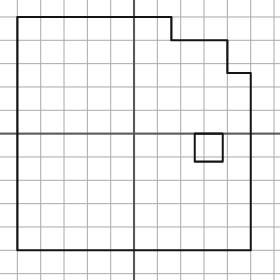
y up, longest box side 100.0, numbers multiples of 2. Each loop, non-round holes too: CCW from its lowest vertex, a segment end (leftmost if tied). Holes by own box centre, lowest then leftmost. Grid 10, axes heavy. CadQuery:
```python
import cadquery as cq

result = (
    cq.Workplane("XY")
    .moveTo(-50.0, -50.0)
    .lineTo(50.0, -50.0)
    .lineTo(50.0, 26.0)
    .lineTo(40.0, 26.0)
    .lineTo(40.0, 40.0)
    .lineTo(16.0, 40.0)
    .lineTo(16.0, 50.0)
    .lineTo(-50.0, 50.0)
    .close()
    .moveTo(26.0, -12.0)
    .lineTo(38.0, -12.0)
    .lineTo(38.0, 0.0)
    .lineTo(26.0, 0.0)
    .close()
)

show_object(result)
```